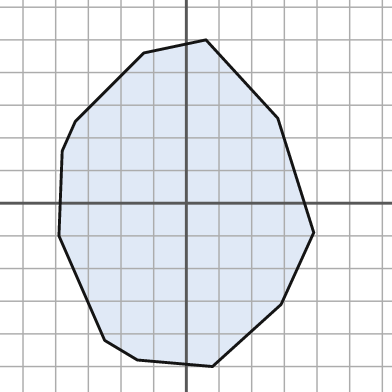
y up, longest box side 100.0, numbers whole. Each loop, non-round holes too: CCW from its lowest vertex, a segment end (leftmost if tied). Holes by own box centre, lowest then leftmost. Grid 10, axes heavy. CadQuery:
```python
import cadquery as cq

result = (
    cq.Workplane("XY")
    .moveTo(8.0, -50.0)
    .lineTo(29.0, -31.0)
    .lineTo(39.0, -9.0)
    .lineTo(28.0, 26.0)
    .lineTo(6.0, 50.0)
    .lineTo(-13.0, 46.0)
    .lineTo(-34.0, 25.0)
    .lineTo(-38.0, 16.0)
    .lineTo(-39.0, -10.0)
    .lineTo(-25.0, -42.0)
    .lineTo(-15.0, -48.0)
    .close()
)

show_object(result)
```